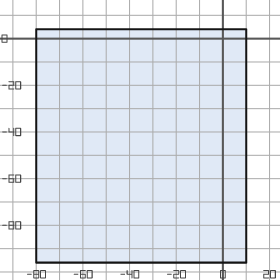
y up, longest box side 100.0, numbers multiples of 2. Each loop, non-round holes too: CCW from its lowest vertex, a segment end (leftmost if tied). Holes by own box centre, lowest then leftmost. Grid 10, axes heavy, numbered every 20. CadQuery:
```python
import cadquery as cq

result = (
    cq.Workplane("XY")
    .moveTo(-80.0, -96.0)
    .lineTo(10.0, -96.0)
    .lineTo(10.0, 4.0)
    .lineTo(-80.0, 4.0)
    .close()
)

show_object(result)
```